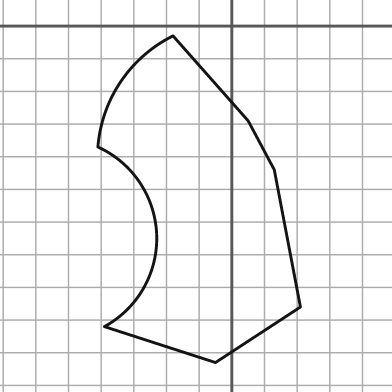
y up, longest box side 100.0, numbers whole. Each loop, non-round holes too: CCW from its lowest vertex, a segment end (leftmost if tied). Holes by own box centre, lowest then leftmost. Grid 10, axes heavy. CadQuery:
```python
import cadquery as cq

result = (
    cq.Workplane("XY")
    .moveTo(-5.0, -103.0)
    .lineTo(21.0, -86.0)
    .lineTo(13.0, -44.0)
    .lineTo(5.0, -29.0)
    .lineTo(-18.0, -3.0)
    .threePointArc((-34.0, -17.0), (-41.0, -37.0))
    .threePointArc((-23.0, -64.0), (-39.0, -92.0))
    .close()
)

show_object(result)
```